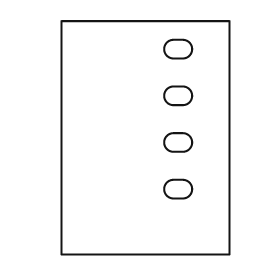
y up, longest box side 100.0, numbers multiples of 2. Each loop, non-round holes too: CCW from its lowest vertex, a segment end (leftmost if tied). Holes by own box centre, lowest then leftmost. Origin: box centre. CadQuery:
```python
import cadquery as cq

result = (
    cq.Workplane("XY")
    .moveTo(-36.0, -50.0)
    .lineTo(36.0, -50.0)
    .lineTo(36.0, 50.0)
    .lineTo(-36.0, 50.0)
    .close()
    .moveTo(12.0, -26.0)
    .lineTo(16.0, -26.0)
    .threePointArc((20.0, -22.0), (16.0, -18.0))
    .lineTo(12.0, -18.0)
    .threePointArc((8.0, -22.0), (12.0, -26.0))
    .close()
    .moveTo(12.0, -6.0)
    .lineTo(16.0, -6.0)
    .threePointArc((20.0, -2.0), (16.0, 2.0))
    .lineTo(12.0, 2.0)
    .threePointArc((8.0, -2.0), (12.0, -6.0))
    .close()
    .moveTo(12.0, 14.0)
    .lineTo(16.0, 14.0)
    .threePointArc((20.0, 18.0), (16.0, 22.0))
    .lineTo(12.0, 22.0)
    .threePointArc((8.0, 18.0), (12.0, 14.0))
    .close()
    .moveTo(12.0, 34.0)
    .lineTo(16.0, 34.0)
    .threePointArc((20.0, 38.0), (16.0, 42.0))
    .lineTo(12.0, 42.0)
    .threePointArc((8.0, 38.0), (12.0, 34.0))
    .close()
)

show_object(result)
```